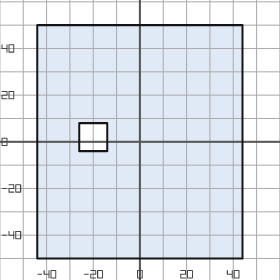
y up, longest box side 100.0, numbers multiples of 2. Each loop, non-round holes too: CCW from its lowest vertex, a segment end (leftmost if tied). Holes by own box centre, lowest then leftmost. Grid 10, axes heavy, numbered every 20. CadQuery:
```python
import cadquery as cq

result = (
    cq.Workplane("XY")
    .moveTo(-44.0, -50.0)
    .lineTo(44.0, -50.0)
    .lineTo(44.0, 50.0)
    .lineTo(-44.0, 50.0)
    .close()
    .moveTo(-26.0, -4.0)
    .lineTo(-14.0, -4.0)
    .lineTo(-14.0, 8.0)
    .lineTo(-26.0, 8.0)
    .close()
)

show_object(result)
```